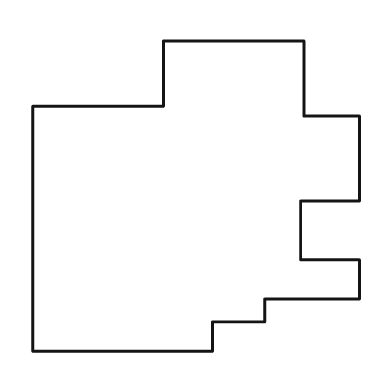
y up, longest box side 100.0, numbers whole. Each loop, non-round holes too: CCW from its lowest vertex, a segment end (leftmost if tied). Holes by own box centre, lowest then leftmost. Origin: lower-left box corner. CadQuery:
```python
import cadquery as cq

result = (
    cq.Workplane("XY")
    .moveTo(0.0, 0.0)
    .lineTo(55.0, 0.0)
    .lineTo(55.0, 9.0)
    .lineTo(71.0, 9.0)
    .lineTo(71.0, 16.0)
    .lineTo(100.0, 16.0)
    .lineTo(100.0, 28.0)
    .lineTo(82.0, 28.0)
    .lineTo(82.0, 46.0)
    .lineTo(100.0, 46.0)
    .lineTo(100.0, 72.0)
    .lineTo(83.0, 72.0)
    .lineTo(83.0, 95.0)
    .lineTo(40.0, 95.0)
    .lineTo(40.0, 75.0)
    .lineTo(0.0, 75.0)
    .close()
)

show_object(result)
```